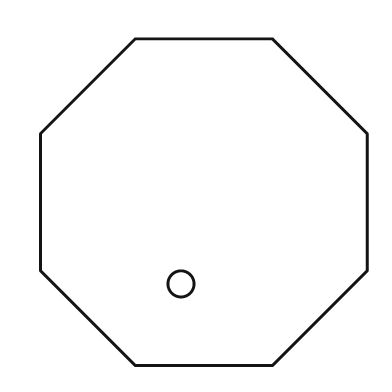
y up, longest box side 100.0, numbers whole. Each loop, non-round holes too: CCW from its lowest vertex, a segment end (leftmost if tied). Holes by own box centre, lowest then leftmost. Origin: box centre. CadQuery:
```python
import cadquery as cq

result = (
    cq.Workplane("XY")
    .moveTo(-21.0, -50.0)
    .lineTo(21.0, -50.0)
    .lineTo(50.0, -21.0)
    .lineTo(50.0, 21.0)
    .lineTo(21.0, 50.0)
    .lineTo(-21.0, 50.0)
    .lineTo(-50.0, 21.0)
    .lineTo(-50.0, -21.0)
    .close()
    .moveTo(-7.0, -25.0)
    .circle(4.0)
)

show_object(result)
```